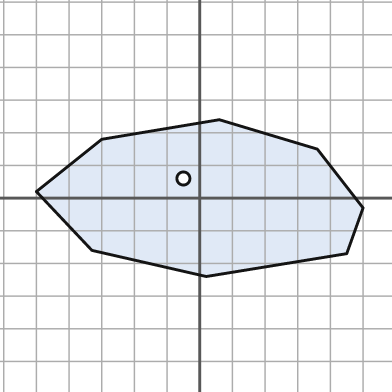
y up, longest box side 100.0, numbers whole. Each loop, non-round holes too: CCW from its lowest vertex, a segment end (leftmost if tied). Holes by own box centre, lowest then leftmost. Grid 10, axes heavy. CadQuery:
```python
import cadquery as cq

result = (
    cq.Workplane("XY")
    .moveTo(2.0, -24.0)
    .lineTo(45.0, -17.0)
    .lineTo(50.0, -3.0)
    .lineTo(36.0, 15.0)
    .lineTo(6.0, 24.0)
    .lineTo(-30.0, 18.0)
    .lineTo(-50.0, 2.0)
    .lineTo(-33.0, -16.0)
    .close()
    .moveTo(-5.0, 6.0)
    .circle(2.0)
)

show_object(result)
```